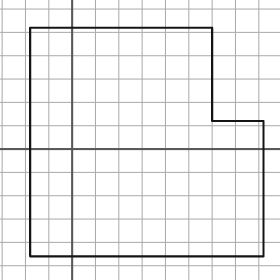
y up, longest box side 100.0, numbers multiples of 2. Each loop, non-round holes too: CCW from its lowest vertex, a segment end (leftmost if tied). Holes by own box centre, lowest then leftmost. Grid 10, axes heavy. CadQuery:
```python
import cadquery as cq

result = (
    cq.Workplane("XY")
    .moveTo(-18.0, -46.0)
    .lineTo(82.0, -46.0)
    .lineTo(82.0, 12.0)
    .lineTo(60.0, 12.0)
    .lineTo(60.0, 52.0)
    .lineTo(-18.0, 52.0)
    .close()
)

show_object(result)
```